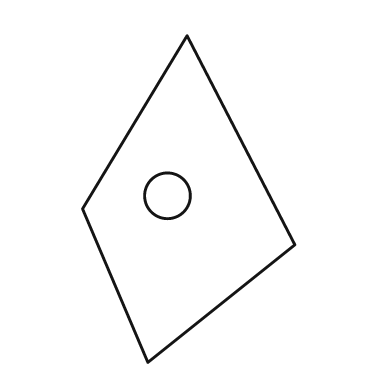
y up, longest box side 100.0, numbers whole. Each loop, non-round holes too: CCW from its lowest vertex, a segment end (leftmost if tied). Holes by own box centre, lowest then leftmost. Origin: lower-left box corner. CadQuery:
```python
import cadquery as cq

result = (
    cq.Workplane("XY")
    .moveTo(20.0, 0.0)
    .lineTo(65.0, 36.0)
    .lineTo(32.0, 100.0)
    .lineTo(0.0, 47.0)
    .close()
    .moveTo(26.0, 51.0)
    .circle(7.0)
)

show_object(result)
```